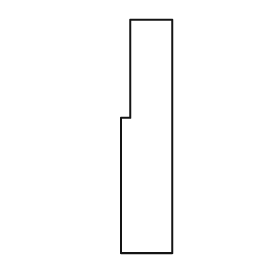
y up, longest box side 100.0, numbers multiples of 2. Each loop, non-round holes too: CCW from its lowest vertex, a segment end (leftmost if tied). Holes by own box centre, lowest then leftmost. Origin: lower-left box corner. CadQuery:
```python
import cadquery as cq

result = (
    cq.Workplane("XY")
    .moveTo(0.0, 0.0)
    .lineTo(22.0, 0.0)
    .lineTo(22.0, 100.0)
    .lineTo(4.0, 100.0)
    .lineTo(4.0, 58.0)
    .lineTo(0.0, 58.0)
    .close()
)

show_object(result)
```